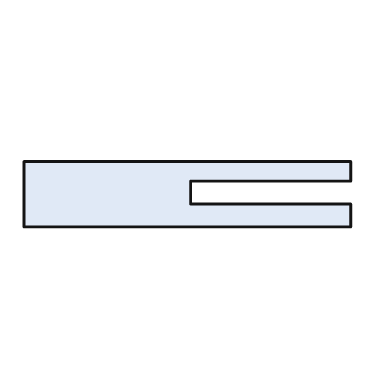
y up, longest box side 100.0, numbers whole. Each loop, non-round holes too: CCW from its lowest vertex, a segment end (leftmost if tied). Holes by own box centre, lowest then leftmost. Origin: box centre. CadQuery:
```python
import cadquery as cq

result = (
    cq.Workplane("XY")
    .moveTo(-50.0, -10.0)
    .lineTo(50.0, -10.0)
    .lineTo(50.0, -3.0)
    .lineTo(1.0, -3.0)
    .lineTo(1.0, 4.0)
    .lineTo(50.0, 4.0)
    .lineTo(50.0, 10.0)
    .lineTo(-50.0, 10.0)
    .close()
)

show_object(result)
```